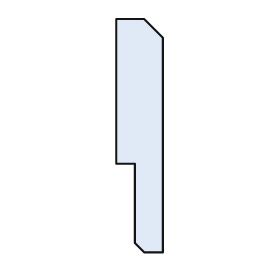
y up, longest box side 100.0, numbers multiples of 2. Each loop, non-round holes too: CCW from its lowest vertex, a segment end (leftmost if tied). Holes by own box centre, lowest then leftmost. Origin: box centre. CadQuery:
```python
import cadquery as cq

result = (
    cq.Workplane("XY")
    .moveTo(2.0, -50.0)
    .lineTo(10.0, -50.0)
    .lineTo(10.0, 42.0)
    .lineTo(2.0, 50.0)
    .lineTo(-10.0, 50.0)
    .lineTo(-10.0, -12.0)
    .lineTo(-2.0, -12.0)
    .lineTo(-2.0, -46.0)
    .close()
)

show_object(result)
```